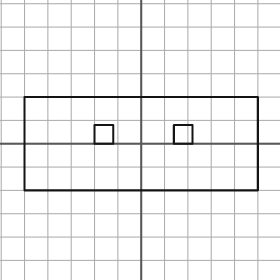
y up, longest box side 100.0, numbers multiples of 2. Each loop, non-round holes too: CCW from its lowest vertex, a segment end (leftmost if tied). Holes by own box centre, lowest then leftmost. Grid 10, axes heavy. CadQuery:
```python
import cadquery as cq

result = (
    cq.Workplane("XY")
    .moveTo(-50.0, -20.0)
    .lineTo(50.0, -20.0)
    .lineTo(50.0, 20.0)
    .lineTo(-50.0, 20.0)
    .close()
    .moveTo(-20.0, 0.0)
    .lineTo(-12.0, 0.0)
    .lineTo(-12.0, 8.0)
    .lineTo(-20.0, 8.0)
    .close()
    .moveTo(14.0, 0.0)
    .lineTo(22.0, 0.0)
    .lineTo(22.0, 8.0)
    .lineTo(14.0, 8.0)
    .close()
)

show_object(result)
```